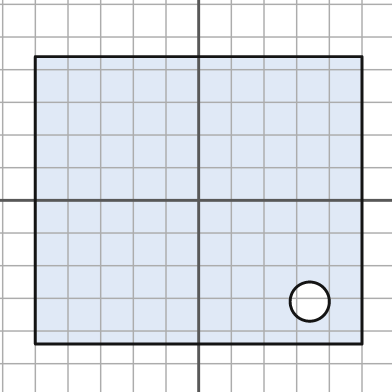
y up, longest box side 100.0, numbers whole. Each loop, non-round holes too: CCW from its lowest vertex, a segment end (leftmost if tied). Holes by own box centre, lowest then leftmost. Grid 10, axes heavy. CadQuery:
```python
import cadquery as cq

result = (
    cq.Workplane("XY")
    .moveTo(-50.0, -44.0)
    .lineTo(50.0, -44.0)
    .lineTo(50.0, 44.0)
    .lineTo(-50.0, 44.0)
    .close()
    .moveTo(34.0, -31.0)
    .circle(6.0)
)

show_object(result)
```